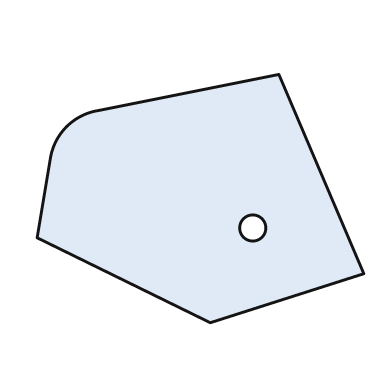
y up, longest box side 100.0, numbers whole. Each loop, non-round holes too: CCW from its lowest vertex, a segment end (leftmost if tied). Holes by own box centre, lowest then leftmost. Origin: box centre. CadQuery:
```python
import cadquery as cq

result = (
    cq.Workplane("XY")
    .moveTo(3.0, -38.0)
    .lineTo(50.0, -23.0)
    .lineTo(24.0, 38.0)
    .lineTo(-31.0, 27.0)
    .threePointArc((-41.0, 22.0), (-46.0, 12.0))
    .lineTo(-50.0, -12.0)
    .close()
    .moveTo(16.0, -9.0)
    .circle(4.0)
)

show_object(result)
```